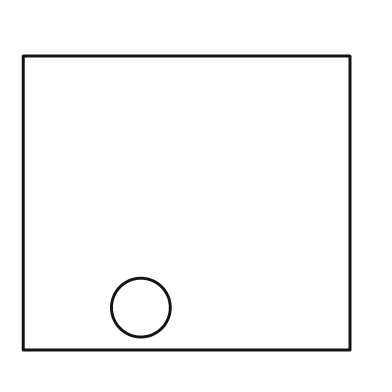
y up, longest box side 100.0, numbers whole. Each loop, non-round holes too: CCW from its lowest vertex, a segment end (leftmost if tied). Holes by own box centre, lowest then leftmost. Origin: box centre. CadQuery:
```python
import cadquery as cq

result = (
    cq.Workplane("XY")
    .moveTo(-50.0, -45.0)
    .lineTo(50.0, -45.0)
    .lineTo(50.0, 45.0)
    .lineTo(-50.0, 45.0)
    .close()
    .moveTo(-14.0, -32.0)
    .circle(9.0)
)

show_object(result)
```